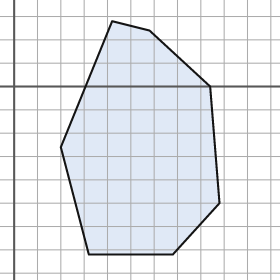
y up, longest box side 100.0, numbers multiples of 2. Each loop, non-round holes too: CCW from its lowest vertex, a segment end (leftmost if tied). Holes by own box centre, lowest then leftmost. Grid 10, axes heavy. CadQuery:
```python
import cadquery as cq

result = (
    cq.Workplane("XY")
    .moveTo(32.0, -72.0)
    .lineTo(68.0, -72.0)
    .lineTo(88.0, -50.0)
    .lineTo(84.0, 0.0)
    .lineTo(58.0, 24.0)
    .lineTo(42.0, 28.0)
    .lineTo(20.0, -26.0)
    .close()
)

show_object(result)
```